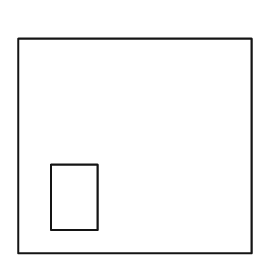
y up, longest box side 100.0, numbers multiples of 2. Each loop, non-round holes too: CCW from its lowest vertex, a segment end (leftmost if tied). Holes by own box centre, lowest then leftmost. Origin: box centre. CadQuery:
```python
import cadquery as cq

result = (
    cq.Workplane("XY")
    .moveTo(-50.0, -46.0)
    .lineTo(50.0, -46.0)
    .lineTo(50.0, 46.0)
    .lineTo(-50.0, 46.0)
    .close()
    .moveTo(-36.0, -36.0)
    .lineTo(-16.0, -36.0)
    .lineTo(-16.0, -8.0)
    .lineTo(-36.0, -8.0)
    .close()
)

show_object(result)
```